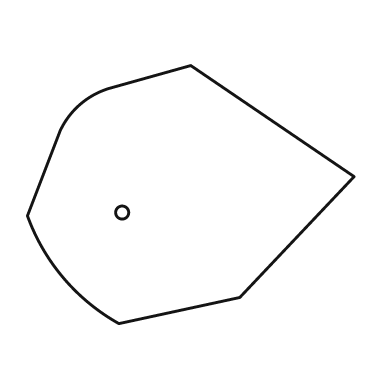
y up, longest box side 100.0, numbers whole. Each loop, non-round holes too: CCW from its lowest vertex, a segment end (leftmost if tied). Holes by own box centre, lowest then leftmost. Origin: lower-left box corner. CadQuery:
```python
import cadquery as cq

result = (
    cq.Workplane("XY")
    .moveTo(28.0, 0.0)
    .lineTo(65.0, 8.0)
    .lineTo(100.0, 45.0)
    .lineTo(50.0, 79.0)
    .lineTo(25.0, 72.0)
    .threePointArc((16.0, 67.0), (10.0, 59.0))
    .lineTo(0.0, 33.0)
    .threePointArc((11.0, 14.0), (28.0, 0.0))
    .close()
    .moveTo(29.0, 34.0)
    .circle(2.0)
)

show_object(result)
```